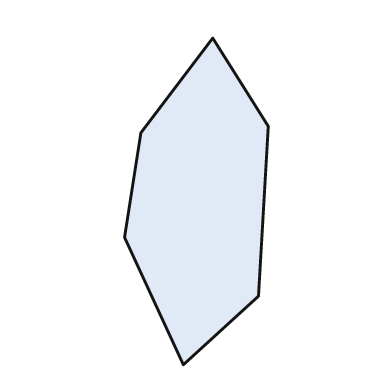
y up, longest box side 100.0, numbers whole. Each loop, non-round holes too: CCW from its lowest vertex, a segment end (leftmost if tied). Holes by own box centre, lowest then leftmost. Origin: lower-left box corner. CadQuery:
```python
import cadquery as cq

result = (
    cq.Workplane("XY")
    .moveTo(18.0, 0.0)
    .lineTo(41.0, 21.0)
    .lineTo(44.0, 73.0)
    .lineTo(27.0, 100.0)
    .lineTo(5.0, 71.0)
    .lineTo(0.0, 39.0)
    .close()
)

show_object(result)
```